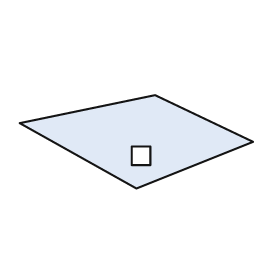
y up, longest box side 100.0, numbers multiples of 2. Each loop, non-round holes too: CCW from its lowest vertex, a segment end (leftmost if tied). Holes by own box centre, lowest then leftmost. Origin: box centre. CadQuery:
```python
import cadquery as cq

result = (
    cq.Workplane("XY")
    .moveTo(0.0, -20.0)
    .lineTo(50.0, 0.0)
    .lineTo(8.0, 20.0)
    .lineTo(-50.0, 8.0)
    .close()
    .moveTo(-2.0, -10.0)
    .lineTo(6.0, -10.0)
    .lineTo(6.0, -2.0)
    .lineTo(-2.0, -2.0)
    .close()
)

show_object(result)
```